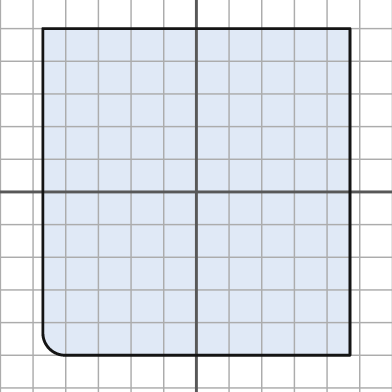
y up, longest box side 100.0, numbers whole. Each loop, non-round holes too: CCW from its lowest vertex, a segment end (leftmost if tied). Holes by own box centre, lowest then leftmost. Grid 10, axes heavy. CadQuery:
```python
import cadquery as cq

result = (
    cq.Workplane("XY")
    .moveTo(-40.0, -50.0)
    .lineTo(47.0, -50.0)
    .lineTo(47.0, 50.0)
    .lineTo(-47.0, 50.0)
    .lineTo(-47.0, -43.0)
    .threePointArc((-45.0, -48.0), (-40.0, -50.0))
    .close()
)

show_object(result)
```